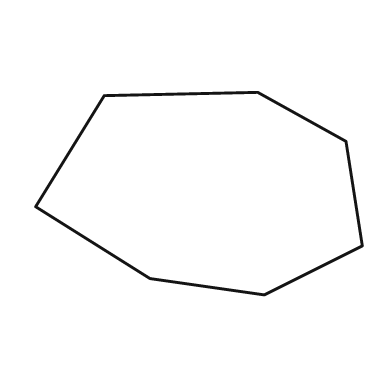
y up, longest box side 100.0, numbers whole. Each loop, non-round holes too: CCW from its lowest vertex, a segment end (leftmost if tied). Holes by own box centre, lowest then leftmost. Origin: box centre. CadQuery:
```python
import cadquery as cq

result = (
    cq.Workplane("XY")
    .moveTo(20.0, -31.0)
    .lineTo(50.0, -16.0)
    .lineTo(45.0, 16.0)
    .lineTo(18.0, 31.0)
    .lineTo(-29.0, 30.0)
    .lineTo(-50.0, -4.0)
    .lineTo(-15.0, -26.0)
    .close()
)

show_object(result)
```